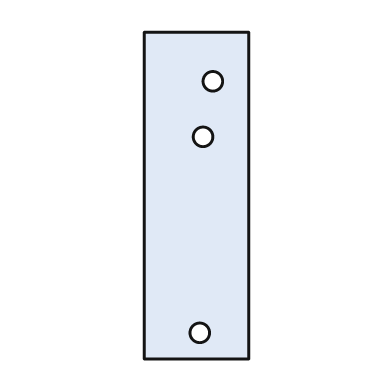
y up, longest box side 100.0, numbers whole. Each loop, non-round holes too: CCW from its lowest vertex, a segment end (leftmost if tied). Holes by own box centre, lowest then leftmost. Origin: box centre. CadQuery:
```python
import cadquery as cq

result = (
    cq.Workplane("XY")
    .moveTo(-16.0, -50.0)
    .lineTo(16.0, -50.0)
    .lineTo(16.0, 50.0)
    .lineTo(-16.0, 50.0)
    .close()
    .moveTo(1.0, -42.0)
    .circle(3.0)
    .moveTo(2.0, 18.0)
    .circle(3.0)
    .moveTo(5.0, 35.0)
    .circle(3.0)
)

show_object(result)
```